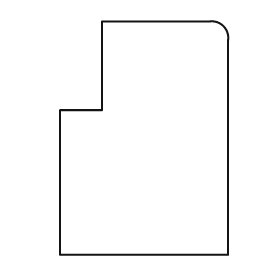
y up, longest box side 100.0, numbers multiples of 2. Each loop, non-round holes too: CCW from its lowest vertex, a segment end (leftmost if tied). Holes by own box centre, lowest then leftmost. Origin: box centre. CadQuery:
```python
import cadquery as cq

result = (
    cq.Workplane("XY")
    .moveTo(-36.0, -50.0)
    .lineTo(36.0, -50.0)
    .lineTo(36.0, 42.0)
    .threePointArc((34.0, 48.0), (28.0, 50.0))
    .lineTo(-18.0, 50.0)
    .lineTo(-18.0, 12.0)
    .lineTo(-36.0, 12.0)
    .close()
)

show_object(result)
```